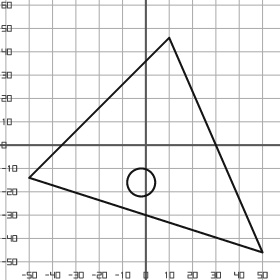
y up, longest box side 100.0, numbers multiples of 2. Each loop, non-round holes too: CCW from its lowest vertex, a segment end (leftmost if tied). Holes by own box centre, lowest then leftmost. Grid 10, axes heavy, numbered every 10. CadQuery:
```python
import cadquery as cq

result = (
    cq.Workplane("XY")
    .moveTo(50.0, -46.0)
    .lineTo(10.0, 46.0)
    .lineTo(-50.0, -14.0)
    .close()
    .moveTo(-2.0, -16.0)
    .circle(6.0)
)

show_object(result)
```